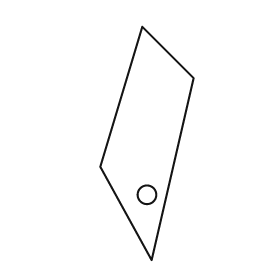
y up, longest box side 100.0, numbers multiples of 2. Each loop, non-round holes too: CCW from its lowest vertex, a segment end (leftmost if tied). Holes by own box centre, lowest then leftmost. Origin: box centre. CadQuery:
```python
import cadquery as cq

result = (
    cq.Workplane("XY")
    .moveTo(2.0, -50.0)
    .lineTo(20.0, 28.0)
    .lineTo(-2.0, 50.0)
    .lineTo(-20.0, -10.0)
    .close()
    .moveTo(0.0, -22.0)
    .circle(4.0)
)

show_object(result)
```